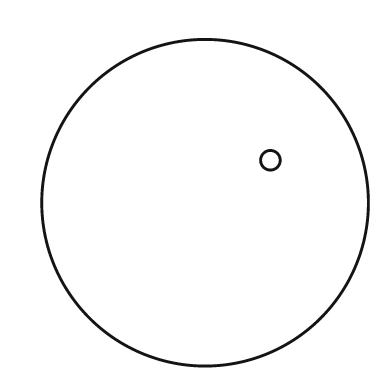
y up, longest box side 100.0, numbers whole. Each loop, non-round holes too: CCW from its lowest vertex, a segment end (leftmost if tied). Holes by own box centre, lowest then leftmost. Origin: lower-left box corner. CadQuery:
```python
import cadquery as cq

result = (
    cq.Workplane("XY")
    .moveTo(50.0, 50.0)
    .circle(50.0)
    .moveTo(70.0, 63.0)
    .circle(3.0)
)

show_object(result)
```